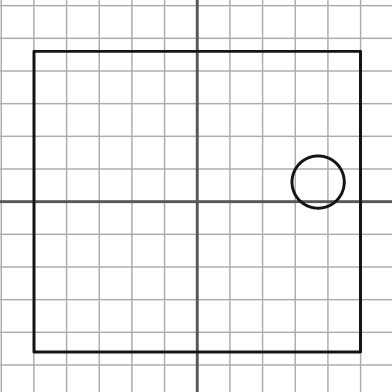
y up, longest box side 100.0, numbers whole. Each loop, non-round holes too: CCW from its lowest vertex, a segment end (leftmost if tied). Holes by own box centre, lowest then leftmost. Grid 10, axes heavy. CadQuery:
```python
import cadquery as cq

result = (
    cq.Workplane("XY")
    .moveTo(-50.0, -46.0)
    .lineTo(50.0, -46.0)
    .lineTo(50.0, 46.0)
    .lineTo(-50.0, 46.0)
    .close()
    .moveTo(37.0, 6.0)
    .circle(8.0)
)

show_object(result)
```